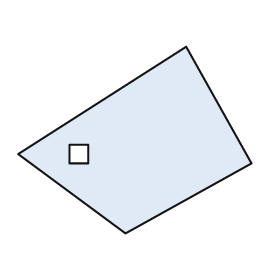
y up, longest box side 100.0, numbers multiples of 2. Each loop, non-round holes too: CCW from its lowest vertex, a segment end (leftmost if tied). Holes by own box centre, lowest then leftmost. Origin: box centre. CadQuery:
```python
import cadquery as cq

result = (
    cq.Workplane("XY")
    .moveTo(-4.0, -40.0)
    .lineTo(50.0, -10.0)
    .lineTo(22.0, 40.0)
    .lineTo(-50.0, -6.0)
    .close()
    .moveTo(-28.0, -10.0)
    .lineTo(-20.0, -10.0)
    .lineTo(-20.0, -2.0)
    .lineTo(-28.0, -2.0)
    .close()
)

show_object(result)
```